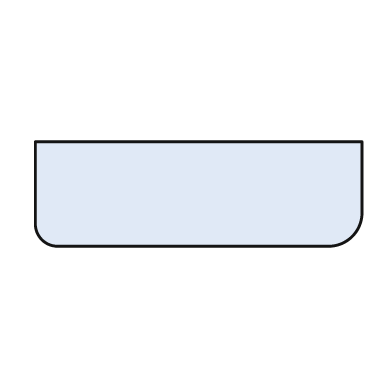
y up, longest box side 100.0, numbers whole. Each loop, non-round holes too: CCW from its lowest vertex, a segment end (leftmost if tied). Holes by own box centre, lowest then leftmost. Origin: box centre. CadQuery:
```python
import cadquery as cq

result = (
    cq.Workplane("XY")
    .moveTo(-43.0, -16.0)
    .lineTo(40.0, -16.0)
    .threePointArc((47.0, -13.0), (50.0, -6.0))
    .lineTo(50.0, 16.0)
    .lineTo(-50.0, 16.0)
    .lineTo(-50.0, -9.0)
    .threePointArc((-48.0, -14.0), (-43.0, -16.0))
    .close()
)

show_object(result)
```